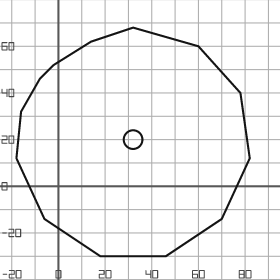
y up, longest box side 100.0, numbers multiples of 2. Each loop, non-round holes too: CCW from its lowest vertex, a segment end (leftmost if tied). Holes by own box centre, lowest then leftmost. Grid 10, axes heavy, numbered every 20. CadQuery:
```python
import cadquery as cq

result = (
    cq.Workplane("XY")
    .moveTo(18.0, -30.0)
    .lineTo(46.0, -30.0)
    .lineTo(70.0, -14.0)
    .lineTo(82.0, 12.0)
    .lineTo(78.0, 40.0)
    .lineTo(60.0, 60.0)
    .lineTo(32.0, 68.0)
    .lineTo(14.0, 62.0)
    .lineTo(-2.0, 52.0)
    .lineTo(-8.0, 46.0)
    .lineTo(-16.0, 32.0)
    .lineTo(-18.0, 12.0)
    .lineTo(-6.0, -14.0)
    .close()
    .moveTo(32.0, 20.0)
    .circle(4.0)
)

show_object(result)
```